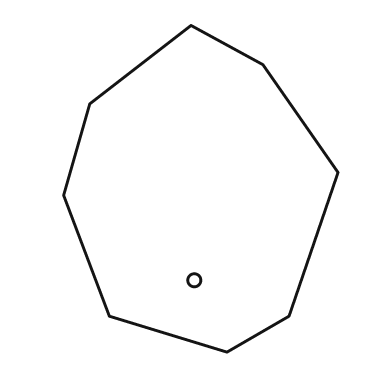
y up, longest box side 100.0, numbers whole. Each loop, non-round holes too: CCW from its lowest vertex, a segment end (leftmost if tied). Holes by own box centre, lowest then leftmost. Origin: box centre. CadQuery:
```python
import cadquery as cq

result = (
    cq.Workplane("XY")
    .moveTo(8.0, -50.0)
    .lineTo(27.0, -39.0)
    .lineTo(42.0, 5.0)
    .lineTo(19.0, 38.0)
    .lineTo(-3.0, 50.0)
    .lineTo(-34.0, 26.0)
    .lineTo(-42.0, -2.0)
    .lineTo(-28.0, -39.0)
    .close()
    .moveTo(-2.0, -28.0)
    .circle(2.0)
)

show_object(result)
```